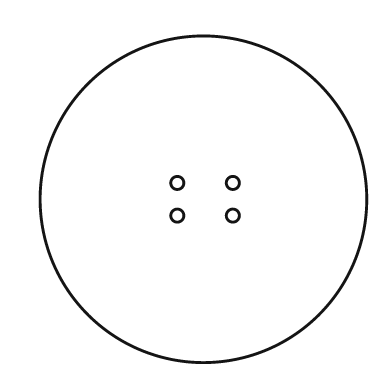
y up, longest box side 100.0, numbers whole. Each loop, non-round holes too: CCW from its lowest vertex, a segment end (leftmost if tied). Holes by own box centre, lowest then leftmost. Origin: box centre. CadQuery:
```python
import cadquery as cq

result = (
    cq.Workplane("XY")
    .moveTo(0.0, 0.0)
    .circle(50.0)
    .moveTo(-8.0, -5.0)
    .circle(2.0)
    .moveTo(9.0, -5.0)
    .circle(2.0)
    .moveTo(-8.0, 5.0)
    .circle(2.0)
    .moveTo(9.0, 5.0)
    .circle(2.0)
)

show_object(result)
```